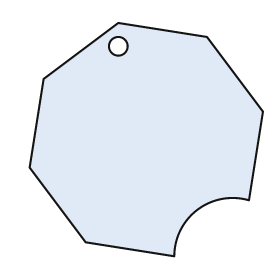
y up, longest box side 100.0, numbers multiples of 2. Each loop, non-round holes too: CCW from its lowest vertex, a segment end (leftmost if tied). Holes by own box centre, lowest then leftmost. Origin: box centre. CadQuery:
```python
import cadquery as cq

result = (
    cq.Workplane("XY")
    .moveTo(12.0, -50.0)
    .threePointArc((22.0, -30.0), (44.0, -26.0))
    .lineTo(50.0, 12.0)
    .lineTo(26.0, 44.0)
    .lineTo(-12.0, 50.0)
    .lineTo(-44.0, 26.0)
    .lineTo(-50.0, -12.0)
    .lineTo(-26.0, -44.0)
    .close()
    .moveTo(-12.0, 40.0)
    .circle(4.0)
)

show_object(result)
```